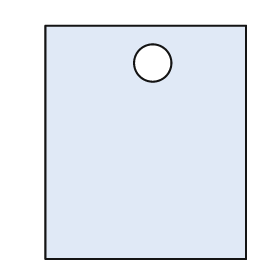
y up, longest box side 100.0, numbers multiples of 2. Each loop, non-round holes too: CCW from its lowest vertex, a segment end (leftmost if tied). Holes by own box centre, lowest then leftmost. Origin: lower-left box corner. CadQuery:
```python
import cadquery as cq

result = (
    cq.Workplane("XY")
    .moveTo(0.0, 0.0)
    .lineTo(86.0, 0.0)
    .lineTo(86.0, 100.0)
    .lineTo(0.0, 100.0)
    .close()
    .moveTo(46.0, 84.0)
    .circle(8.0)
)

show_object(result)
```